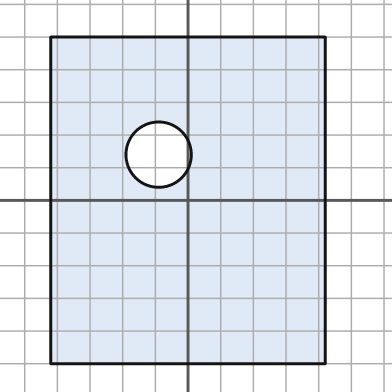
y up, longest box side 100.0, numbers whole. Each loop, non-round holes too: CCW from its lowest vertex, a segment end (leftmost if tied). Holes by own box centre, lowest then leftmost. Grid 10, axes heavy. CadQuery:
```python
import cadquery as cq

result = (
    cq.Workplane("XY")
    .moveTo(-42.0, -50.0)
    .lineTo(42.0, -50.0)
    .lineTo(42.0, 50.0)
    .lineTo(-42.0, 50.0)
    .close()
    .moveTo(-9.0, 14.0)
    .circle(10.0)
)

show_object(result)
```